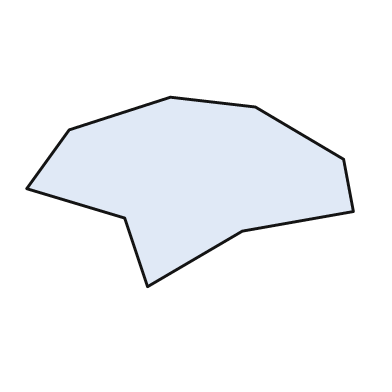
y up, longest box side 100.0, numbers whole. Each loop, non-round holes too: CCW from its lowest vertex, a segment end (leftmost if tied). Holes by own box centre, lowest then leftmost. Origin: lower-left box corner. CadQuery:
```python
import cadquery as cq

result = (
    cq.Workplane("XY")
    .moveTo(37.0, 0.0)
    .lineTo(66.0, 17.0)
    .lineTo(100.0, 23.0)
    .lineTo(97.0, 39.0)
    .lineTo(70.0, 55.0)
    .lineTo(44.0, 58.0)
    .lineTo(13.0, 48.0)
    .lineTo(0.0, 30.0)
    .lineTo(30.0, 21.0)
    .close()
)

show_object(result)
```